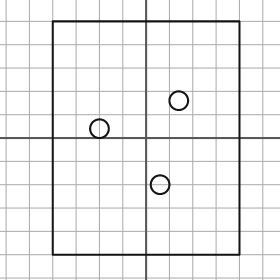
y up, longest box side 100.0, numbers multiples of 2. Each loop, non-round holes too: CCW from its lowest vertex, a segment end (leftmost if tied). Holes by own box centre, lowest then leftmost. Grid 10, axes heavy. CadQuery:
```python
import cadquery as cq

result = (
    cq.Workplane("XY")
    .moveTo(-40.0, -50.0)
    .lineTo(40.0, -50.0)
    .lineTo(40.0, 50.0)
    .lineTo(-40.0, 50.0)
    .close()
    .moveTo(6.0, -20.0)
    .circle(4.0)
    .moveTo(-20.0, 4.0)
    .circle(4.0)
    .moveTo(14.0, 16.0)
    .circle(4.0)
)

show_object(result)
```